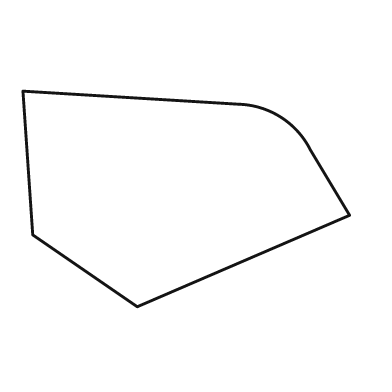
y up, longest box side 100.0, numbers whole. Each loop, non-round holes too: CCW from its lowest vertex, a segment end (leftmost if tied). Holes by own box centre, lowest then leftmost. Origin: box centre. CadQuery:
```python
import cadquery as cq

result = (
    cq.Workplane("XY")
    .moveTo(-15.0, -33.0)
    .lineTo(50.0, -5.0)
    .lineTo(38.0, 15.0)
    .threePointArc((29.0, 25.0), (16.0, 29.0))
    .lineTo(-50.0, 33.0)
    .lineTo(-47.0, -11.0)
    .close()
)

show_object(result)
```